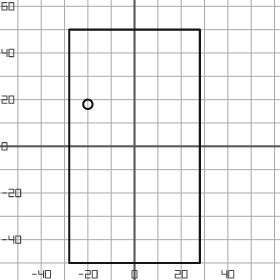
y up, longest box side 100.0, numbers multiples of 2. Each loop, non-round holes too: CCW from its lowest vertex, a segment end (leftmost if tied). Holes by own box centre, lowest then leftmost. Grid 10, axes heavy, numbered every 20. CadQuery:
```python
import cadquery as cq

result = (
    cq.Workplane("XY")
    .moveTo(-28.0, -50.0)
    .lineTo(28.0, -50.0)
    .lineTo(28.0, 50.0)
    .lineTo(-28.0, 50.0)
    .close()
    .moveTo(-20.0, 18.0)
    .circle(2.0)
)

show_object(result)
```